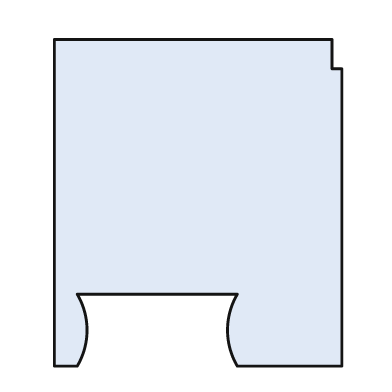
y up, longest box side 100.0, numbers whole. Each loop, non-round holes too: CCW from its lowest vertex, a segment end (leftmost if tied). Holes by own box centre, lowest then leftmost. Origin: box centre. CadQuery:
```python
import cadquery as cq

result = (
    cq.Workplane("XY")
    .moveTo(-44.0, -50.0)
    .lineTo(-37.0, -50.0)
    .threePointArc((-34.0, -39.0), (-37.0, -28.0))
    .lineTo(12.0, -28.0)
    .threePointArc((9.0, -39.0), (12.0, -50.0))
    .lineTo(44.0, -50.0)
    .lineTo(44.0, 41.0)
    .lineTo(41.0, 41.0)
    .lineTo(41.0, 50.0)
    .lineTo(-44.0, 50.0)
    .close()
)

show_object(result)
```